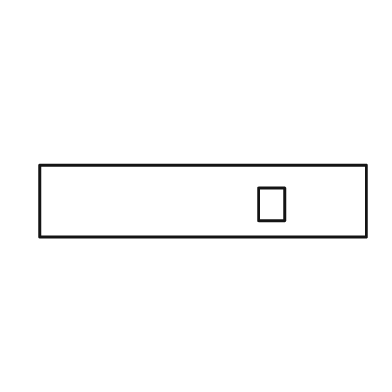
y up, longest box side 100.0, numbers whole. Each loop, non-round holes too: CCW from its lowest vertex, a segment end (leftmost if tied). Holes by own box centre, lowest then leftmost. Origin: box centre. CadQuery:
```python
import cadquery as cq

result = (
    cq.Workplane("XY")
    .moveTo(-50.0, -11.0)
    .lineTo(50.0, -11.0)
    .lineTo(50.0, 11.0)
    .lineTo(-50.0, 11.0)
    .close()
    .moveTo(17.0, -6.0)
    .lineTo(25.0, -6.0)
    .lineTo(25.0, 4.0)
    .lineTo(17.0, 4.0)
    .close()
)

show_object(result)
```